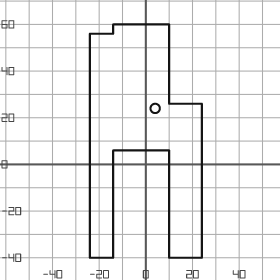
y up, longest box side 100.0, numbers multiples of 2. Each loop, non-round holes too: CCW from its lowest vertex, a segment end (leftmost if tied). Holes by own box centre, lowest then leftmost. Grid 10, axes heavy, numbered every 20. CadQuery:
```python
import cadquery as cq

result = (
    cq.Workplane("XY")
    .moveTo(-24.0, -40.0)
    .lineTo(-14.0, -40.0)
    .lineTo(-14.0, 6.0)
    .lineTo(10.0, 6.0)
    .lineTo(10.0, -40.0)
    .lineTo(24.0, -40.0)
    .lineTo(24.0, 26.0)
    .lineTo(10.0, 26.0)
    .lineTo(10.0, 60.0)
    .lineTo(-14.0, 60.0)
    .lineTo(-14.0, 56.0)
    .lineTo(-24.0, 56.0)
    .close()
    .moveTo(4.0, 24.0)
    .circle(2.0)
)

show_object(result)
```